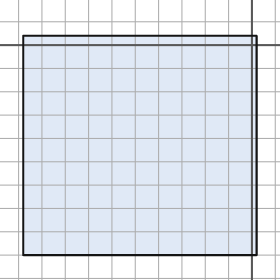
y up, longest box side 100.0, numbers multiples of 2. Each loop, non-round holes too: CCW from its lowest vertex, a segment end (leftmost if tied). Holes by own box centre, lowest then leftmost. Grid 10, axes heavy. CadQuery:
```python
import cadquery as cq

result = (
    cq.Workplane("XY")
    .moveTo(-98.0, -90.0)
    .lineTo(2.0, -90.0)
    .lineTo(2.0, 4.0)
    .lineTo(-98.0, 4.0)
    .close()
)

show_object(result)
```